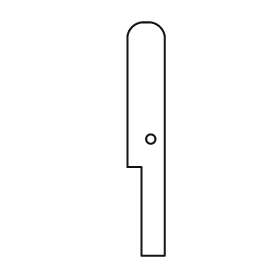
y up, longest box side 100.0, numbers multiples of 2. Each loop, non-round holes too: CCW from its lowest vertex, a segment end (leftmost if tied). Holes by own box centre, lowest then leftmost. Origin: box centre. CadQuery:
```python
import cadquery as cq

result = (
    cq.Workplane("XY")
    .moveTo(-2.0, -50.0)
    .lineTo(8.0, -50.0)
    .lineTo(8.0, 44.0)
    .threePointArc((6.0, 48.0), (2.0, 50.0))
    .lineTo(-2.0, 50.0)
    .threePointArc((-6.0, 48.0), (-8.0, 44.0))
    .lineTo(-8.0, -12.0)
    .lineTo(-2.0, -12.0)
    .close()
    .moveTo(2.0, 0.0)
    .circle(2.0)
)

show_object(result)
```